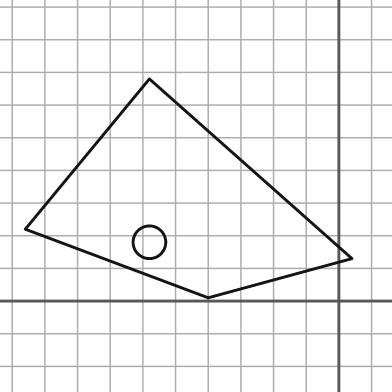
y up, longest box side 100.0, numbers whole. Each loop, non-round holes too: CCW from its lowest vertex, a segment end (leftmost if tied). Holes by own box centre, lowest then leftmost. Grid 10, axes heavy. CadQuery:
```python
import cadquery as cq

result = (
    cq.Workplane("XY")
    .moveTo(-40.0, 1.0)
    .lineTo(4.0, 13.0)
    .lineTo(-58.0, 68.0)
    .lineTo(-96.0, 22.0)
    .close()
    .moveTo(-58.0, 18.0)
    .circle(5.0)
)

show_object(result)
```